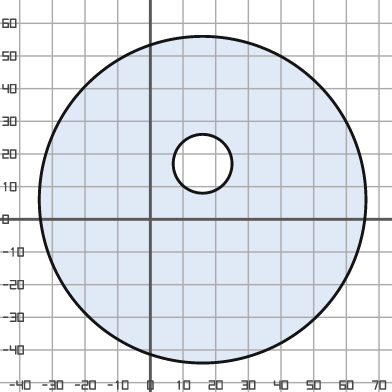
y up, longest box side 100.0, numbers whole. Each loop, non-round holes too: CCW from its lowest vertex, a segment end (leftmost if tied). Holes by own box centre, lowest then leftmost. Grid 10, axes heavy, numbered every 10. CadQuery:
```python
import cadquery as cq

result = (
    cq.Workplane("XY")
    .moveTo(16.0, 6.0)
    .circle(50.0)
    .moveTo(16.0, 17.0)
    .circle(9.0)
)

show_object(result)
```